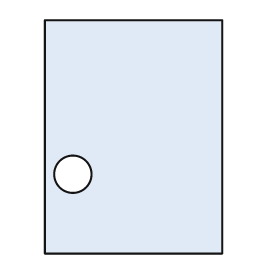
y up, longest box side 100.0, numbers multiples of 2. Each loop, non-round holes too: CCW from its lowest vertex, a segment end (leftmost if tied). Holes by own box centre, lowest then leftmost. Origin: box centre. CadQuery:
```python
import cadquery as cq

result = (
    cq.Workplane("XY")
    .moveTo(-38.0, -50.0)
    .lineTo(38.0, -50.0)
    .lineTo(38.0, 50.0)
    .lineTo(-38.0, 50.0)
    .close()
    .moveTo(-26.0, -16.0)
    .circle(8.0)
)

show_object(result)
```